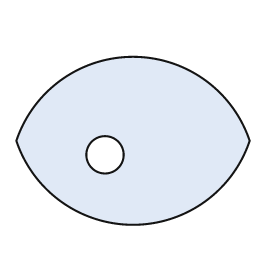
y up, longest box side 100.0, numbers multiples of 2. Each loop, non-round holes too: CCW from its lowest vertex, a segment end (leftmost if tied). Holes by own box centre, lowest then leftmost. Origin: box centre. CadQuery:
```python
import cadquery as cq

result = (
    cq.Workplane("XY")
    .moveTo(-50.0, 0.0)
    .threePointArc((0.0, -36.0), (50.0, 0.0))
    .threePointArc((0.0, 36.0), (-50.0, 0.0))
    .close()
    .moveTo(-12.0, -6.0)
    .circle(8.0)
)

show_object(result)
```